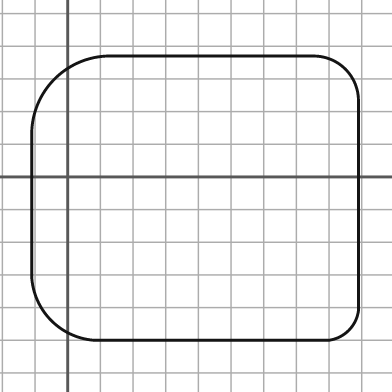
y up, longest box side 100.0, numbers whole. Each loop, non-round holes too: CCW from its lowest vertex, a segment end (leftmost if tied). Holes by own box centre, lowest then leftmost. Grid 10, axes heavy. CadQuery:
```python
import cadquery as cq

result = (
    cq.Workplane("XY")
    .moveTo(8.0, -50.0)
    .lineTo(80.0, -50.0)
    .threePointArc((86.0, -47.0), (89.0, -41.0))
    .lineTo(89.0, 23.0)
    .threePointArc((85.0, 33.0), (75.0, 37.0))
    .lineTo(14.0, 37.0)
    .threePointArc((-4.0, 30.0), (-11.0, 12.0))
    .lineTo(-11.0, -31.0)
    .threePointArc((-5.0, -44.0), (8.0, -50.0))
    .close()
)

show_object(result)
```